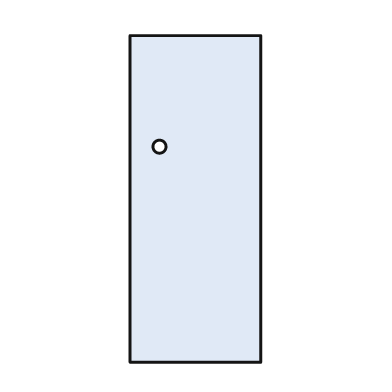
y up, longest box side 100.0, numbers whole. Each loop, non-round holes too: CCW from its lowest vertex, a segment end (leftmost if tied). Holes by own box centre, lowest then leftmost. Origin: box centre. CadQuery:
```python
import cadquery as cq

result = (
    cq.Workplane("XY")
    .moveTo(-20.0, -50.0)
    .lineTo(20.0, -50.0)
    .lineTo(20.0, 50.0)
    .lineTo(-20.0, 50.0)
    .close()
    .moveTo(-11.0, 16.0)
    .circle(2.0)
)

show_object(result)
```